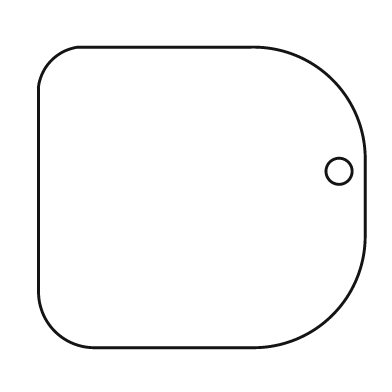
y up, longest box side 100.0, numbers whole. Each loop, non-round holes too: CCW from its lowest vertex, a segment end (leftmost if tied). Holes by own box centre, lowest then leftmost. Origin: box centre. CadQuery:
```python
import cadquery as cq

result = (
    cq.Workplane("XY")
    .moveTo(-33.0, -46.0)
    .lineTo(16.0, -46.0)
    .threePointArc((40.0, -36.0), (50.0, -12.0))
    .lineTo(50.0, 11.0)
    .threePointArc((40.0, 36.0), (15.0, 46.0))
    .lineTo(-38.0, 46.0)
    .threePointArc((-46.0, 42.0), (-50.0, 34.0))
    .lineTo(-50.0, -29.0)
    .threePointArc((-45.0, -41.0), (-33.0, -46.0))
    .close()
    .moveTo(42.0, 8.0)
    .circle(4.0)
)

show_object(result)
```